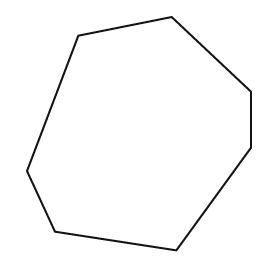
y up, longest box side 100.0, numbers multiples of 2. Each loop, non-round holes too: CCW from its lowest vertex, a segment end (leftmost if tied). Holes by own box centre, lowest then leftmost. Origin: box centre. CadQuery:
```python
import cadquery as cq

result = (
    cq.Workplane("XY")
    .moveTo(16.0, -50.0)
    .lineTo(48.0, -6.0)
    .lineTo(48.0, 18.0)
    .lineTo(14.0, 50.0)
    .lineTo(-26.0, 42.0)
    .lineTo(-48.0, -16.0)
    .lineTo(-36.0, -42.0)
    .close()
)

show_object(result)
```